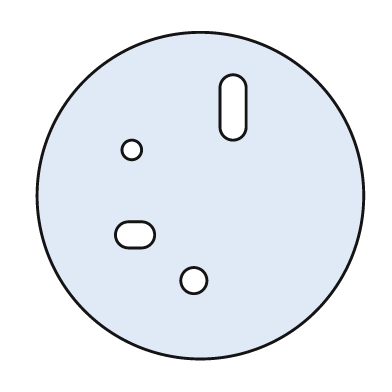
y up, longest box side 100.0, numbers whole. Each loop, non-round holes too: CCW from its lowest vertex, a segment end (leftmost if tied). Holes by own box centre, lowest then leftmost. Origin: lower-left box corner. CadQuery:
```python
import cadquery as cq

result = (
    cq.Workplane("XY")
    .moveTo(50.0, 50.0)
    .circle(50.0)
    .moveTo(48.0, 24.0)
    .circle(4.0)
    .moveTo(28.0, 34.0)
    .lineTo(32.0, 34.0)
    .threePointArc((36.0, 38.0), (32.0, 42.0))
    .lineTo(28.0, 42.0)
    .threePointArc((24.0, 38.0), (28.0, 34.0))
    .close()
    .moveTo(29.0, 64.0)
    .circle(3.0)
    .moveTo(56.0, 71.0)
    .threePointArc((60.0, 67.0), (64.0, 71.0))
    .lineTo(64.0, 83.0)
    .threePointArc((60.0, 87.0), (56.0, 83.0))
    .close()
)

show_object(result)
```